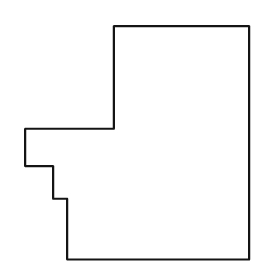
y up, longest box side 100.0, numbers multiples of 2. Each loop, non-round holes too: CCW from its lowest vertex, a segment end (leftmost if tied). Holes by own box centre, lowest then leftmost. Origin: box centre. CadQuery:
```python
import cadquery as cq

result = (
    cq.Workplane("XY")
    .moveTo(-30.0, -50.0)
    .lineTo(48.0, -50.0)
    .lineTo(48.0, 50.0)
    .lineTo(-10.0, 50.0)
    .lineTo(-10.0, 6.0)
    .lineTo(-48.0, 6.0)
    .lineTo(-48.0, -10.0)
    .lineTo(-36.0, -10.0)
    .lineTo(-36.0, -24.0)
    .lineTo(-30.0, -24.0)
    .close()
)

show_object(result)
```